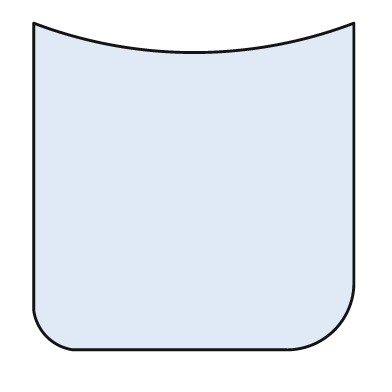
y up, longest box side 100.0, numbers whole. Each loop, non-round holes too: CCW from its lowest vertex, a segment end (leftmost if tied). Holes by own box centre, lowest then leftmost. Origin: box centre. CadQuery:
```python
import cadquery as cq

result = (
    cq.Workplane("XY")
    .moveTo(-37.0, -50.0)
    .lineTo(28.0, -50.0)
    .threePointArc((43.0, -44.0), (49.0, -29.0))
    .lineTo(49.0, 50.0)
    .threePointArc((0.0, 41.0), (-49.0, 50.0))
    .lineTo(-49.0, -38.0)
    .threePointArc((-45.0, -46.0), (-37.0, -50.0))
    .close()
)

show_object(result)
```